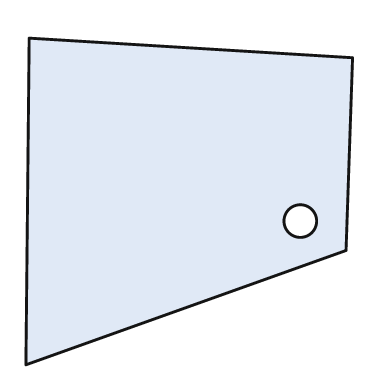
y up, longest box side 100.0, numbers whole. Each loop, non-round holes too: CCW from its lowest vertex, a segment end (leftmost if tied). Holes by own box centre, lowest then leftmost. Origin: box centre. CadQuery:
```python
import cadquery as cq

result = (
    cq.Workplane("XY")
    .moveTo(-50.0, -50.0)
    .lineTo(48.0, -15.0)
    .lineTo(50.0, 44.0)
    .lineTo(-49.0, 50.0)
    .close()
    .moveTo(34.0, -6.0)
    .circle(5.0)
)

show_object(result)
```